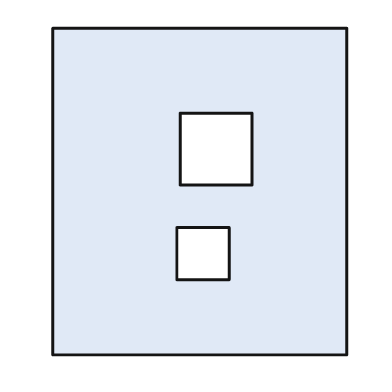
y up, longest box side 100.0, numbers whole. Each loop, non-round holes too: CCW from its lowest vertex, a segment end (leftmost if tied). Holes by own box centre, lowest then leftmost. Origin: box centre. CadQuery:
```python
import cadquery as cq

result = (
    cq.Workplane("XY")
    .moveTo(-45.0, -50.0)
    .lineTo(45.0, -50.0)
    .lineTo(45.0, 50.0)
    .lineTo(-45.0, 50.0)
    .close()
    .moveTo(-7.0, -27.0)
    .lineTo(9.0, -27.0)
    .lineTo(9.0, -11.0)
    .lineTo(-7.0, -11.0)
    .close()
    .moveTo(-6.0, 2.0)
    .lineTo(16.0, 2.0)
    .lineTo(16.0, 24.0)
    .lineTo(-6.0, 24.0)
    .close()
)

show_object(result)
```